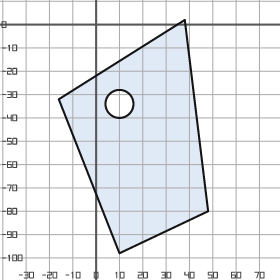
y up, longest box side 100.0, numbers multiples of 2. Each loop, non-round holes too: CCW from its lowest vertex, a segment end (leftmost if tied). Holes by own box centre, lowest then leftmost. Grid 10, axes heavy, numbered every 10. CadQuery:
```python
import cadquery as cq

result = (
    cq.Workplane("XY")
    .moveTo(10.0, -98.0)
    .lineTo(48.0, -80.0)
    .lineTo(38.0, 2.0)
    .lineTo(-16.0, -32.0)
    .close()
    .moveTo(10.0, -34.0)
    .circle(6.0)
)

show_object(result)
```